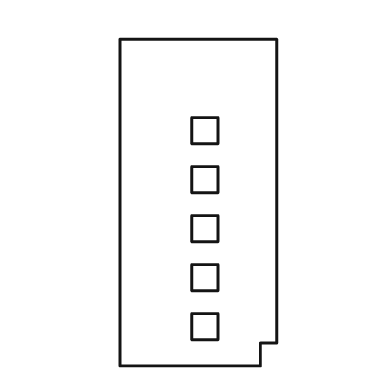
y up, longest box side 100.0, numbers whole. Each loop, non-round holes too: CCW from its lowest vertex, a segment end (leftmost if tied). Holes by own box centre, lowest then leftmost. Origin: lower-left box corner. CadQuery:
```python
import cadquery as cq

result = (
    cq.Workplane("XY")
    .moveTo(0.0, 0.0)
    .lineTo(43.0, 0.0)
    .lineTo(43.0, 7.0)
    .lineTo(48.0, 7.0)
    .lineTo(48.0, 100.0)
    .lineTo(0.0, 100.0)
    .close()
    .moveTo(22.0, 8.0)
    .lineTo(30.0, 8.0)
    .lineTo(30.0, 16.0)
    .lineTo(22.0, 16.0)
    .close()
    .moveTo(22.0, 23.0)
    .lineTo(30.0, 23.0)
    .lineTo(30.0, 31.0)
    .lineTo(22.0, 31.0)
    .close()
    .moveTo(22.0, 38.0)
    .lineTo(30.0, 38.0)
    .lineTo(30.0, 46.0)
    .lineTo(22.0, 46.0)
    .close()
    .moveTo(22.0, 53.0)
    .lineTo(30.0, 53.0)
    .lineTo(30.0, 61.0)
    .lineTo(22.0, 61.0)
    .close()
    .moveTo(22.0, 68.0)
    .lineTo(30.0, 68.0)
    .lineTo(30.0, 76.0)
    .lineTo(22.0, 76.0)
    .close()
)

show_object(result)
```